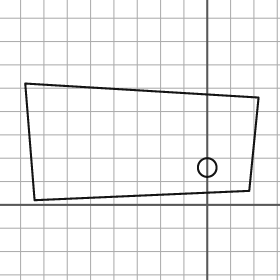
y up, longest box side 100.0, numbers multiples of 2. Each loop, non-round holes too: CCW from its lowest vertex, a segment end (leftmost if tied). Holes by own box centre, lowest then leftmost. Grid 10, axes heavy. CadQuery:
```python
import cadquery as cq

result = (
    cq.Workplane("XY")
    .moveTo(-74.0, 2.0)
    .lineTo(18.0, 6.0)
    .lineTo(22.0, 46.0)
    .lineTo(-78.0, 52.0)
    .close()
    .moveTo(0.0, 16.0)
    .circle(4.0)
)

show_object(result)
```